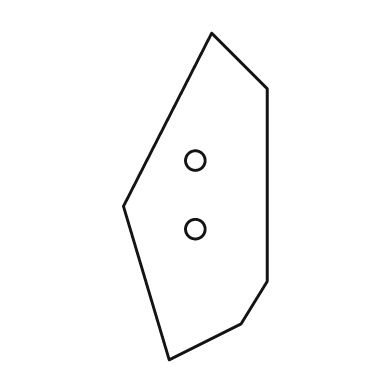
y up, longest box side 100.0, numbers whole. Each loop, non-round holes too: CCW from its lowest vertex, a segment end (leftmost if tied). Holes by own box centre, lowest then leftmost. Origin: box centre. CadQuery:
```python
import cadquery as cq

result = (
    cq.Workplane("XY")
    .moveTo(-8.0, -50.0)
    .lineTo(14.0, -39.0)
    .lineTo(22.0, -26.0)
    .lineTo(22.0, 33.0)
    .lineTo(5.0, 50.0)
    .lineTo(-22.0, -3.0)
    .close()
    .moveTo(0.0, -10.0)
    .circle(3.0)
    .moveTo(0.0, 11.0)
    .circle(3.0)
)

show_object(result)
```